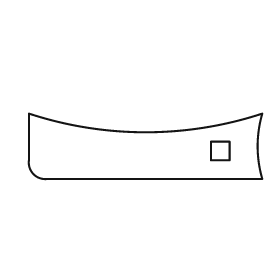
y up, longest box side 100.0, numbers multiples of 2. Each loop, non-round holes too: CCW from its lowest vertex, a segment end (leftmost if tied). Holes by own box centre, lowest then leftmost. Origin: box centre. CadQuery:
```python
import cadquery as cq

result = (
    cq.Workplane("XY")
    .moveTo(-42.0, -14.0)
    .lineTo(50.0, -14.0)
    .threePointArc((48.0, 0.0), (50.0, 14.0))
    .threePointArc((0.0, 6.0), (-50.0, 14.0))
    .lineTo(-50.0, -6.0)
    .threePointArc((-48.0, -12.0), (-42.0, -14.0))
    .close()
    .moveTo(28.0, -6.0)
    .lineTo(36.0, -6.0)
    .lineTo(36.0, 2.0)
    .lineTo(28.0, 2.0)
    .close()
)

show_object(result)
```